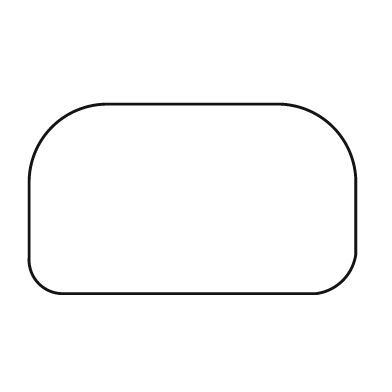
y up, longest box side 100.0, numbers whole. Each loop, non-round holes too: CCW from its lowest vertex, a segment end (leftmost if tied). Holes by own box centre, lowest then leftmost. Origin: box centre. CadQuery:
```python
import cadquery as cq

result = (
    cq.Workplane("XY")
    .moveTo(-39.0, -29.0)
    .lineTo(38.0, -29.0)
    .threePointArc((46.0, -25.0), (50.0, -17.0))
    .lineTo(50.0, 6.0)
    .threePointArc((43.0, 22.0), (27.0, 29.0))
    .lineTo(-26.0, 29.0)
    .threePointArc((-43.0, 22.0), (-50.0, 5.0))
    .lineTo(-50.0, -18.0)
    .threePointArc((-47.0, -26.0), (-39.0, -29.0))
    .close()
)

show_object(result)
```